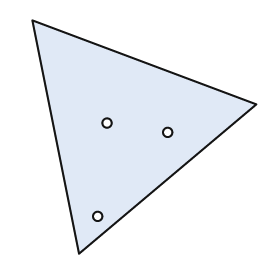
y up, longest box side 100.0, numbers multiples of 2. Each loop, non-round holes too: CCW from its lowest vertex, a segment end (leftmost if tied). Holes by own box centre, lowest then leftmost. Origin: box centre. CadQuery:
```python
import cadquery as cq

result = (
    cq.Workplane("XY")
    .moveTo(-28.0, -50.0)
    .lineTo(48.0, 14.0)
    .lineTo(-48.0, 50.0)
    .close()
    .moveTo(-20.0, -34.0)
    .circle(2.0)
    .moveTo(10.0, 2.0)
    .circle(2.0)
    .moveTo(-16.0, 6.0)
    .circle(2.0)
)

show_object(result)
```